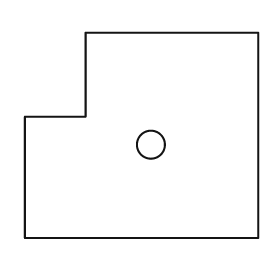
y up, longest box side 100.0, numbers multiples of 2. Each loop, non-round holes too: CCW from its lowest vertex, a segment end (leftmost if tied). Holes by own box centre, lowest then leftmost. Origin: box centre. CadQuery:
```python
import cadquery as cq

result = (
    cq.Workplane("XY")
    .moveTo(-50.0, -44.0)
    .lineTo(50.0, -44.0)
    .lineTo(50.0, 44.0)
    .lineTo(-24.0, 44.0)
    .lineTo(-24.0, 8.0)
    .lineTo(-50.0, 8.0)
    .close()
    .moveTo(4.0, -4.0)
    .circle(6.0)
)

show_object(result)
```